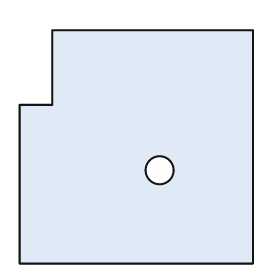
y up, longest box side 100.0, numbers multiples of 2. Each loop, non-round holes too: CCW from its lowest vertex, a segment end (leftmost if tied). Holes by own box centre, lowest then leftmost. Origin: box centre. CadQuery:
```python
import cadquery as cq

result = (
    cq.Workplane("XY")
    .moveTo(-50.0, -50.0)
    .lineTo(50.0, -50.0)
    .lineTo(50.0, 50.0)
    .lineTo(-36.0, 50.0)
    .lineTo(-36.0, 18.0)
    .lineTo(-50.0, 18.0)
    .close()
    .moveTo(10.0, -10.0)
    .circle(6.0)
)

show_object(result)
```